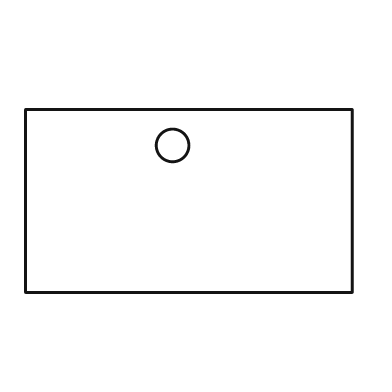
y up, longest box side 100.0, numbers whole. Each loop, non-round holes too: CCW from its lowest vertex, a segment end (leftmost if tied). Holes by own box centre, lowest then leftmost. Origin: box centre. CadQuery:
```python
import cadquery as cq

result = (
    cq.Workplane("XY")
    .moveTo(-50.0, -28.0)
    .lineTo(50.0, -28.0)
    .lineTo(50.0, 28.0)
    .lineTo(-50.0, 28.0)
    .close()
    .moveTo(-5.0, 17.0)
    .circle(5.0)
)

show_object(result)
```